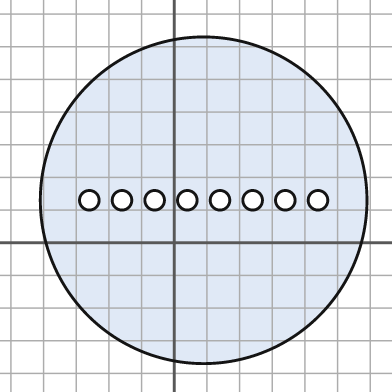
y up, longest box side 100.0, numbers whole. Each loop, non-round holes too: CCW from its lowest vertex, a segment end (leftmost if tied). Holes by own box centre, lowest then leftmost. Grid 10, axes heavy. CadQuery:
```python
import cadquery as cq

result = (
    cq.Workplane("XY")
    .moveTo(9.0, 13.0)
    .circle(50.0)
    .moveTo(-26.0, 13.0)
    .circle(3.0)
    .moveTo(-16.0, 13.0)
    .circle(3.0)
    .moveTo(-6.0, 13.0)
    .circle(3.0)
    .moveTo(4.0, 13.0)
    .circle(3.0)
    .moveTo(14.0, 13.0)
    .circle(3.0)
    .moveTo(24.0, 13.0)
    .circle(3.0)
    .moveTo(34.0, 13.0)
    .circle(3.0)
    .moveTo(44.0, 13.0)
    .circle(3.0)
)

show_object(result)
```